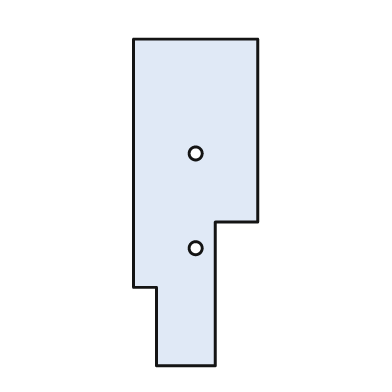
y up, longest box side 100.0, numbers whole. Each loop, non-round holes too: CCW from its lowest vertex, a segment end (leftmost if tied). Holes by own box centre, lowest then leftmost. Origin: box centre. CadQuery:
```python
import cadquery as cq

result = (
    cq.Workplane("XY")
    .moveTo(-12.0, -50.0)
    .lineTo(6.0, -50.0)
    .lineTo(6.0, -6.0)
    .lineTo(19.0, -6.0)
    .lineTo(19.0, 50.0)
    .lineTo(-19.0, 50.0)
    .lineTo(-19.0, -26.0)
    .lineTo(-12.0, -26.0)
    .close()
    .moveTo(0.0, -14.0)
    .circle(2.0)
    .moveTo(0.0, 15.0)
    .circle(2.0)
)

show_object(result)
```